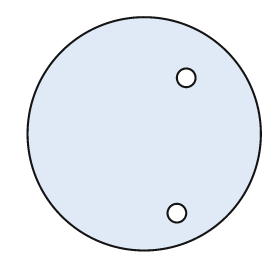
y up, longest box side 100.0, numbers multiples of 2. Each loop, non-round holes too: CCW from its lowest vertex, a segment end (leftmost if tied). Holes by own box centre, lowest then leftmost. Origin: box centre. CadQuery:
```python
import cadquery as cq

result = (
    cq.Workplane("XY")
    .moveTo(0.0, 0.0)
    .circle(50.0)
    .moveTo(14.0, -34.0)
    .circle(4.0)
    .moveTo(18.0, 24.0)
    .circle(4.0)
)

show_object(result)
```